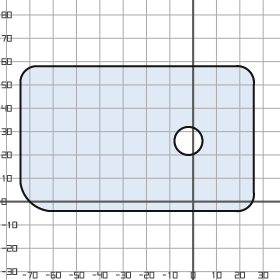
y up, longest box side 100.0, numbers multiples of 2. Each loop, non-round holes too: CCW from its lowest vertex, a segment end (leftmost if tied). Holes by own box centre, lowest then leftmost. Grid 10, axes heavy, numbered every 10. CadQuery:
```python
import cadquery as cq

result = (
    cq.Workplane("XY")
    .moveTo(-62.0, -4.0)
    .lineTo(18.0, -4.0)
    .threePointArc((24.0, -2.0), (26.0, 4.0))
    .lineTo(26.0, 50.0)
    .threePointArc((24.0, 56.0), (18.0, 58.0))
    .lineTo(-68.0, 58.0)
    .threePointArc((-72.0, 56.0), (-74.0, 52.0))
    .lineTo(-74.0, 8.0)
    .threePointArc((-70.0, 0.0), (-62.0, -4.0))
    .close()
    .moveTo(-2.0, 26.0)
    .circle(6.0)
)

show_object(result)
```